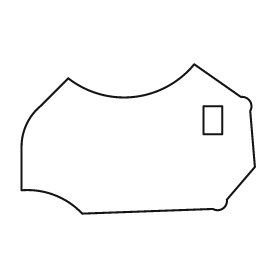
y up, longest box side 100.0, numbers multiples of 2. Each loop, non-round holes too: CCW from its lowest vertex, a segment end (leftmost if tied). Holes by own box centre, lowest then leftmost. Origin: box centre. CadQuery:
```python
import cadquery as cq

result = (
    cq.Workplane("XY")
    .moveTo(-24.0, -32.0)
    .lineTo(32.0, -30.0)
    .threePointArc((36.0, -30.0), (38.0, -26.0))
    .lineTo(50.0, -12.0)
    .lineTo(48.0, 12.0)
    .threePointArc((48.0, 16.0), (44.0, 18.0))
    .lineTo(24.0, 32.0)
    .threePointArc((-2.0, 18.0), (-30.0, 26.0))
    .lineTo(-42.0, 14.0)
    .threePointArc((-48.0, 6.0), (-50.0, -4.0))
    .lineTo(-50.0, -22.0)
    .threePointArc((-36.0, -24.0), (-24.0, -32.0))
    .close()
    .moveTo(28.0, 2.0)
    .lineTo(36.0, 2.0)
    .lineTo(36.0, 14.0)
    .lineTo(28.0, 14.0)
    .close()
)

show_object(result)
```